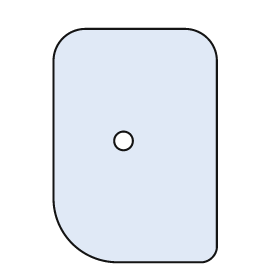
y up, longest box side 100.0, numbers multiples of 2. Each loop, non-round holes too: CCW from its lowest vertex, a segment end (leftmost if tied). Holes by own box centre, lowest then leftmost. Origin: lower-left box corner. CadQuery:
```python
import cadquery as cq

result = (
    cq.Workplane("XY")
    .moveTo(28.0, 0.0)
    .lineTo(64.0, 0.0)
    .threePointArc((68.0, 2.0), (70.0, 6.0))
    .lineTo(70.0, 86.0)
    .threePointArc((66.0, 96.0), (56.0, 100.0))
    .lineTo(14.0, 100.0)
    .threePointArc((4.0, 96.0), (0.0, 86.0))
    .lineTo(0.0, 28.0)
    .threePointArc((8.0, 8.0), (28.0, 0.0))
    .close()
    .moveTo(30.0, 52.0)
    .circle(4.0)
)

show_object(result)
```